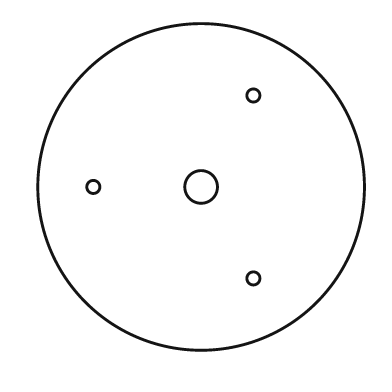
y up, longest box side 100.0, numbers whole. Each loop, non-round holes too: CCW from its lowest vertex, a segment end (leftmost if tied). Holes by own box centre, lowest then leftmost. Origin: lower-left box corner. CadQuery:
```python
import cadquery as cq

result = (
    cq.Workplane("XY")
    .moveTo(50.0, 50.0)
    .circle(50.0)
    .moveTo(66.0, 22.0)
    .circle(2.0)
    .moveTo(17.0, 50.0)
    .circle(2.0)
    .moveTo(50.0, 50.0)
    .circle(5.0)
    .moveTo(66.0, 78.0)
    .circle(2.0)
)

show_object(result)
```